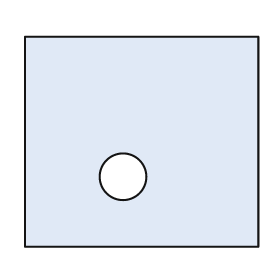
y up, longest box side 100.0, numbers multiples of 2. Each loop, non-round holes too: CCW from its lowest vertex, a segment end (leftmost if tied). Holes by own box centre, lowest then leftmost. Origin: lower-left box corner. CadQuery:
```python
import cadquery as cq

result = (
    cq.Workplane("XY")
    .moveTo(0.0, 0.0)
    .lineTo(100.0, 0.0)
    .lineTo(100.0, 90.0)
    .lineTo(0.0, 90.0)
    .close()
    .moveTo(42.0, 30.0)
    .circle(10.0)
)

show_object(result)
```